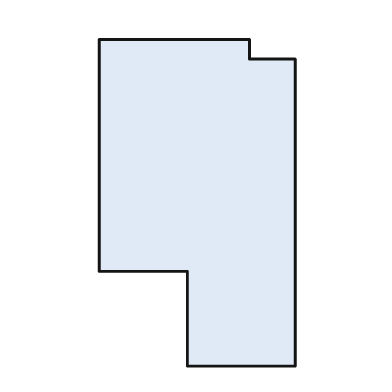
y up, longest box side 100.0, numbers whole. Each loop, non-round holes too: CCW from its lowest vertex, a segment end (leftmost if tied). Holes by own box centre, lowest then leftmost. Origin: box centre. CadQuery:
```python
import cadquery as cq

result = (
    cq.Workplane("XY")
    .moveTo(-3.0, -50.0)
    .lineTo(30.0, -50.0)
    .lineTo(30.0, 44.0)
    .lineTo(16.0, 44.0)
    .lineTo(16.0, 50.0)
    .lineTo(-30.0, 50.0)
    .lineTo(-30.0, -21.0)
    .lineTo(-3.0, -21.0)
    .close()
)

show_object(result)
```